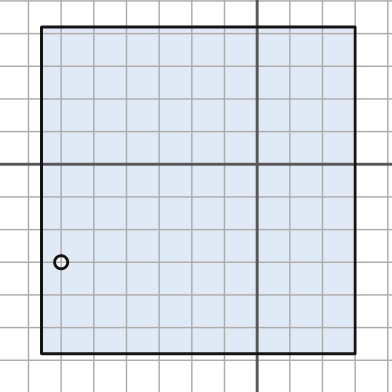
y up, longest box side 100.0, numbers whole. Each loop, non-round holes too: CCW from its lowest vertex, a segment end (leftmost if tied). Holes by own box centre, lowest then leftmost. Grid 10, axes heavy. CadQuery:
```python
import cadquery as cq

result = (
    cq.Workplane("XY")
    .moveTo(-66.0, -58.0)
    .lineTo(30.0, -58.0)
    .lineTo(30.0, 42.0)
    .lineTo(-66.0, 42.0)
    .close()
    .moveTo(-60.0, -30.0)
    .circle(2.0)
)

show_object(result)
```